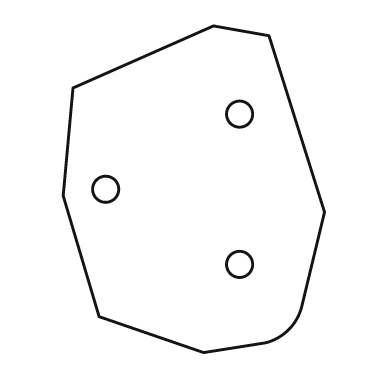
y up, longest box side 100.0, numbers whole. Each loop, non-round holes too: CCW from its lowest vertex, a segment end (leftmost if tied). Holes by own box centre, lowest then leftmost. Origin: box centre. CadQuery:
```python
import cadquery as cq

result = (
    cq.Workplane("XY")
    .moveTo(3.0, -50.0)
    .lineTo(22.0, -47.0)
    .threePointArc((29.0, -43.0), (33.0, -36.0))
    .lineTo(40.0, -7.0)
    .lineTo(23.0, 47.0)
    .lineTo(6.0, 50.0)
    .lineTo(-37.0, 31.0)
    .lineTo(-40.0, -2.0)
    .lineTo(-29.0, -39.0)
    .close()
    .moveTo(14.0, -23.0)
    .circle(4.0)
    .moveTo(-27.0, 0.0)
    .circle(4.0)
    .moveTo(14.0, 23.0)
    .circle(4.0)
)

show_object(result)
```